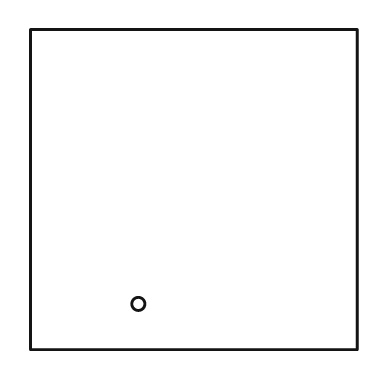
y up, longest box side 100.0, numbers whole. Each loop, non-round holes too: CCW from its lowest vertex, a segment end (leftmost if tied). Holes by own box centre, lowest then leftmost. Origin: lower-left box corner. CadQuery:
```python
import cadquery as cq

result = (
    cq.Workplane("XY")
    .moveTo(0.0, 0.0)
    .lineTo(100.0, 0.0)
    .lineTo(100.0, 98.0)
    .lineTo(0.0, 98.0)
    .close()
    .moveTo(33.0, 14.0)
    .circle(2.0)
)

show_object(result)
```